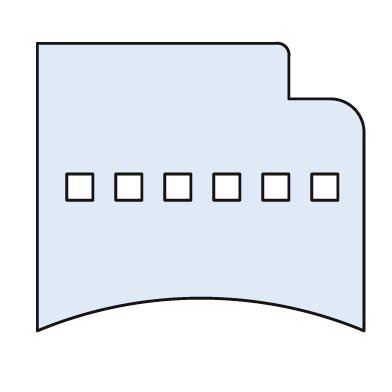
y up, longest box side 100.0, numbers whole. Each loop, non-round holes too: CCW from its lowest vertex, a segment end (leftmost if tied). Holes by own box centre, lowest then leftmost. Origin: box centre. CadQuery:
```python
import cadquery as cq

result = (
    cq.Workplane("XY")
    .moveTo(-50.0, -44.0)
    .threePointArc((0.0, -34.0), (50.0, -44.0))
    .lineTo(50.0, 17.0)
    .threePointArc((47.0, 24.0), (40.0, 27.0))
    .lineTo(27.0, 27.0)
    .lineTo(27.0, 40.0)
    .threePointArc((26.0, 43.0), (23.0, 44.0))
    .lineTo(-50.0, 44.0)
    .close()
    .moveTo(-41.0, -4.0)
    .lineTo(-33.0, -4.0)
    .lineTo(-33.0, 4.0)
    .lineTo(-41.0, 4.0)
    .close()
    .moveTo(-26.0, -4.0)
    .lineTo(-18.0, -4.0)
    .lineTo(-18.0, 4.0)
    .lineTo(-26.0, 4.0)
    .close()
    .moveTo(-11.0, -4.0)
    .lineTo(-3.0, -4.0)
    .lineTo(-3.0, 4.0)
    .lineTo(-11.0, 4.0)
    .close()
    .moveTo(4.0, -4.0)
    .lineTo(12.0, -4.0)
    .lineTo(12.0, 4.0)
    .lineTo(4.0, 4.0)
    .close()
    .moveTo(19.0, -4.0)
    .lineTo(27.0, -4.0)
    .lineTo(27.0, 4.0)
    .lineTo(19.0, 4.0)
    .close()
    .moveTo(34.0, -4.0)
    .lineTo(42.0, -4.0)
    .lineTo(42.0, 4.0)
    .lineTo(34.0, 4.0)
    .close()
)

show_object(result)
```